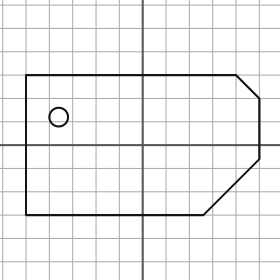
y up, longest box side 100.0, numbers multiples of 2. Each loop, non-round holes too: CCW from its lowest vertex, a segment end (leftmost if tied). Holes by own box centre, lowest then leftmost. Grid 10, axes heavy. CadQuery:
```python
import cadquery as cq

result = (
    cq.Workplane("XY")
    .moveTo(-50.0, -30.0)
    .lineTo(26.0, -30.0)
    .lineTo(50.0, -6.0)
    .lineTo(50.0, 20.0)
    .lineTo(40.0, 30.0)
    .lineTo(-50.0, 30.0)
    .close()
    .moveTo(-36.0, 12.0)
    .circle(4.0)
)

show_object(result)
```